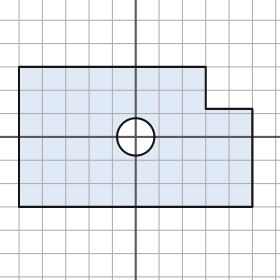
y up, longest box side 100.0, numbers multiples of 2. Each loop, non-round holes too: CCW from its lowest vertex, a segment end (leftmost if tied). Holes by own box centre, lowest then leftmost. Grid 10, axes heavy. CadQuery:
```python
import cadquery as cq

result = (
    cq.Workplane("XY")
    .moveTo(-50.0, -30.0)
    .lineTo(50.0, -30.0)
    .lineTo(50.0, 12.0)
    .lineTo(30.0, 12.0)
    .lineTo(30.0, 30.0)
    .lineTo(-50.0, 30.0)
    .close()
    .moveTo(0.0, 0.0)
    .circle(8.0)
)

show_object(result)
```